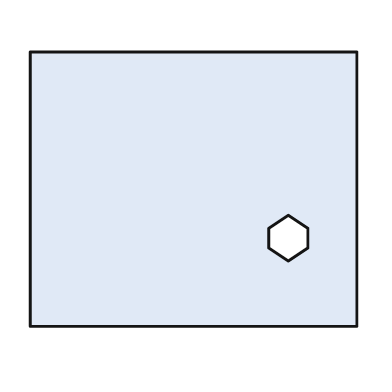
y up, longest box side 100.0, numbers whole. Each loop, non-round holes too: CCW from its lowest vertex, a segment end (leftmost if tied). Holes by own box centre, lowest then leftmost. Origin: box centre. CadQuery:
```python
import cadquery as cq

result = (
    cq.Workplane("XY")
    .moveTo(-50.0, -42.0)
    .lineTo(50.0, -42.0)
    .lineTo(50.0, 42.0)
    .lineTo(-50.0, 42.0)
    .close()
    .moveTo(29.0, -22.0)
    .lineTo(35.0, -18.0)
    .lineTo(35.0, -12.0)
    .lineTo(29.0, -8.0)
    .lineTo(23.0, -12.0)
    .lineTo(23.0, -18.0)
    .close()
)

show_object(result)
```